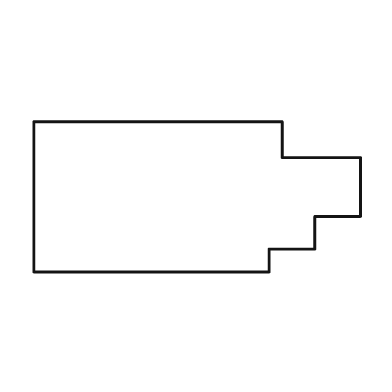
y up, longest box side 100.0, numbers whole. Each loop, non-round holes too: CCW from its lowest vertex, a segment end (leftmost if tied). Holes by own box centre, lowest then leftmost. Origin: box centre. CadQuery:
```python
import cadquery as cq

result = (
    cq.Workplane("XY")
    .moveTo(-50.0, -23.0)
    .lineTo(22.0, -23.0)
    .lineTo(22.0, -16.0)
    .lineTo(36.0, -16.0)
    .lineTo(36.0, -6.0)
    .lineTo(50.0, -6.0)
    .lineTo(50.0, 12.0)
    .lineTo(26.0, 12.0)
    .lineTo(26.0, 23.0)
    .lineTo(-50.0, 23.0)
    .close()
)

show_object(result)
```